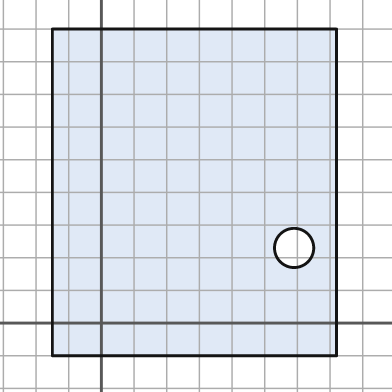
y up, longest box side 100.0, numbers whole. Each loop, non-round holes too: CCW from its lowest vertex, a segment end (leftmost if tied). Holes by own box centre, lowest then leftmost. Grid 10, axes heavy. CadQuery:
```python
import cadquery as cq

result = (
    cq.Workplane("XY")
    .moveTo(-15.0, -10.0)
    .lineTo(72.0, -10.0)
    .lineTo(72.0, 90.0)
    .lineTo(-15.0, 90.0)
    .close()
    .moveTo(59.0, 23.0)
    .circle(6.0)
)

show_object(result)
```